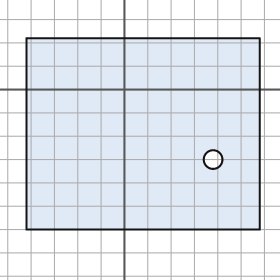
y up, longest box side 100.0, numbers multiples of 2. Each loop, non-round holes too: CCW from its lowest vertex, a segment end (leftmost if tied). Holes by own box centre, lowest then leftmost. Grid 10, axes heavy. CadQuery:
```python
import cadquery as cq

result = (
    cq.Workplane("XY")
    .moveTo(-42.0, -60.0)
    .lineTo(58.0, -60.0)
    .lineTo(58.0, 22.0)
    .lineTo(-42.0, 22.0)
    .close()
    .moveTo(38.0, -30.0)
    .circle(4.0)
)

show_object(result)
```